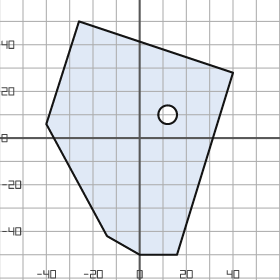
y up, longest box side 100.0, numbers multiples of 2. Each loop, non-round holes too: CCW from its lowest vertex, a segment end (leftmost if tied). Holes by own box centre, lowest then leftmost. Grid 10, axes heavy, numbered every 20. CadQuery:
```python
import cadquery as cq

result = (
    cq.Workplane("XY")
    .moveTo(0.0, -50.0)
    .lineTo(16.0, -50.0)
    .lineTo(40.0, 28.0)
    .lineTo(-26.0, 50.0)
    .lineTo(-40.0, 6.0)
    .lineTo(-14.0, -42.0)
    .close()
    .moveTo(12.0, 10.0)
    .circle(4.0)
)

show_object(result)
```